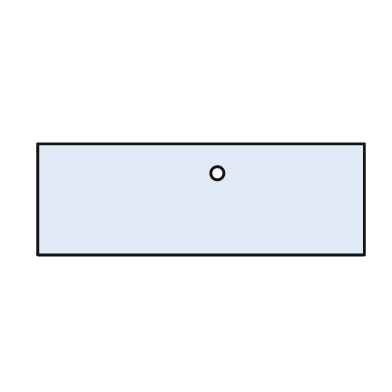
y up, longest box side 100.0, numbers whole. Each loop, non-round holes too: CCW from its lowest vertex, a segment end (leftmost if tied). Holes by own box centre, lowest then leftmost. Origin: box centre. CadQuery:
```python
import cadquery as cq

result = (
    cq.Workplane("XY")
    .moveTo(-50.0, -17.0)
    .lineTo(50.0, -17.0)
    .lineTo(50.0, 17.0)
    .lineTo(-50.0, 17.0)
    .close()
    .moveTo(5.0, 8.0)
    .circle(2.0)
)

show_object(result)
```